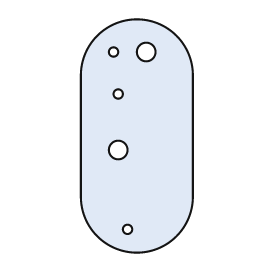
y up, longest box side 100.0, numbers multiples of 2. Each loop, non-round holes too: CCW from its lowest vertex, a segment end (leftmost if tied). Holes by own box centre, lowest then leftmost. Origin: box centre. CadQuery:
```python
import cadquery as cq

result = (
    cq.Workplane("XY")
    .moveTo(-24.0, -26.0)
    .threePointArc((0.0, -50.0), (24.0, -26.0))
    .lineTo(24.0, 26.0)
    .threePointArc((0.0, 50.0), (-24.0, 26.0))
    .close()
    .moveTo(-4.0, -40.0)
    .circle(2.0)
    .moveTo(-8.0, -6.0)
    .circle(4.0)
    .moveTo(-8.0, 18.0)
    .circle(2.0)
    .moveTo(-10.0, 36.0)
    .circle(2.0)
    .moveTo(4.0, 36.0)
    .circle(4.0)
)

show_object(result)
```